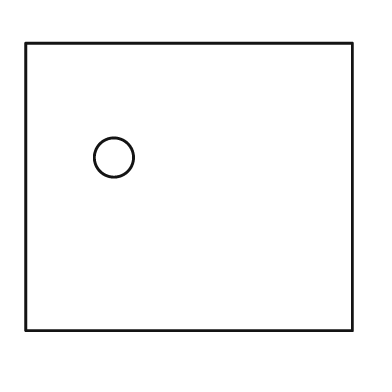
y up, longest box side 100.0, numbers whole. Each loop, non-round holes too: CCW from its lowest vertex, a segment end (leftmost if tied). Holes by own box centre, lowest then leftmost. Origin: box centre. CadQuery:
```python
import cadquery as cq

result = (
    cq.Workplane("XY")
    .moveTo(-50.0, -44.0)
    .lineTo(50.0, -44.0)
    .lineTo(50.0, 44.0)
    .lineTo(-50.0, 44.0)
    .close()
    .moveTo(-23.0, 9.0)
    .circle(6.0)
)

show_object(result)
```